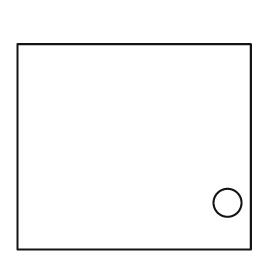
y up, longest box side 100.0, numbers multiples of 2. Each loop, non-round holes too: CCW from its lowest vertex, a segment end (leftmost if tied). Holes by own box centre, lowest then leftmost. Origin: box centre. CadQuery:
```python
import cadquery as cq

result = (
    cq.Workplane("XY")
    .moveTo(-50.0, -44.0)
    .lineTo(50.0, -44.0)
    .lineTo(50.0, 44.0)
    .lineTo(-50.0, 44.0)
    .close()
    .moveTo(40.0, -24.0)
    .circle(6.0)
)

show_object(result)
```